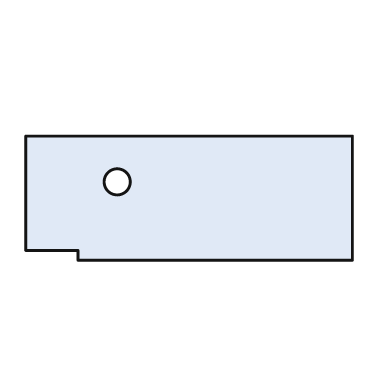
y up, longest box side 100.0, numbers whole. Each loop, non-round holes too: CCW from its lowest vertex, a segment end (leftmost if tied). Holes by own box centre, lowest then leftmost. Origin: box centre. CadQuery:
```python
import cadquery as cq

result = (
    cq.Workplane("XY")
    .moveTo(-34.0, -19.0)
    .lineTo(50.0, -19.0)
    .lineTo(50.0, 19.0)
    .lineTo(-50.0, 19.0)
    .lineTo(-50.0, -16.0)
    .lineTo(-34.0, -16.0)
    .close()
    .moveTo(-22.0, 5.0)
    .circle(4.0)
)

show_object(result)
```